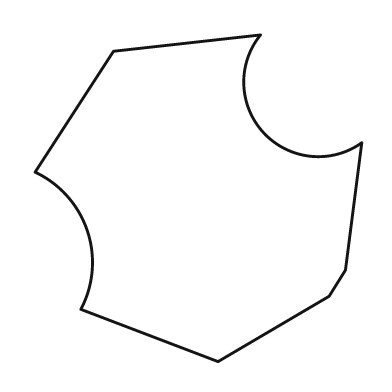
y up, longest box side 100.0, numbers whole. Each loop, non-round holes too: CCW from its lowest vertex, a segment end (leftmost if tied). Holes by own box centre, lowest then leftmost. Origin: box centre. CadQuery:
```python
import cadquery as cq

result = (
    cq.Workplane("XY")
    .moveTo(6.0, -50.0)
    .lineTo(40.0, -30.0)
    .lineTo(45.0, -22.0)
    .lineTo(50.0, 17.0)
    .threePointArc((20.0, 20.0), (19.0, 50.0))
    .lineTo(-26.0, 45.0)
    .lineTo(-50.0, 8.0)
    .threePointArc((-34.0, -10.0), (-36.0, -34.0))
    .close()
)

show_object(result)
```